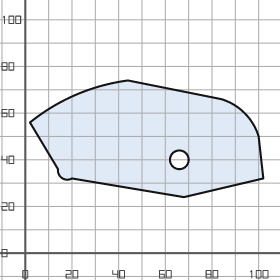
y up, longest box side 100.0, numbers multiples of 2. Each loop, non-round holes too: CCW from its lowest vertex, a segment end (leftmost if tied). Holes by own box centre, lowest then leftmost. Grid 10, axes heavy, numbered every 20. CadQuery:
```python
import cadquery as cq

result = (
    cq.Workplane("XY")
    .moveTo(68.0, 24.0)
    .lineTo(102.0, 32.0)
    .lineTo(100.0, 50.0)
    .threePointArc((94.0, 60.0), (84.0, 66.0))
    .lineTo(44.0, 74.0)
    .threePointArc((22.0, 68.0), (2.0, 56.0))
    .lineTo(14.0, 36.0)
    .threePointArc((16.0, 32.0), (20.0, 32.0))
    .close()
    .moveTo(66.0, 40.0)
    .circle(4.0)
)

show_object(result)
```